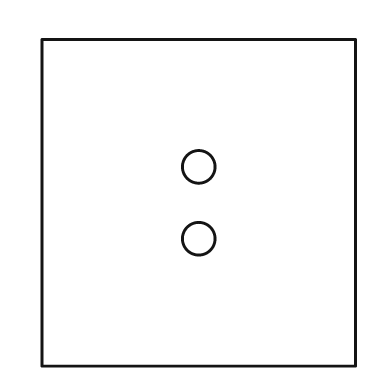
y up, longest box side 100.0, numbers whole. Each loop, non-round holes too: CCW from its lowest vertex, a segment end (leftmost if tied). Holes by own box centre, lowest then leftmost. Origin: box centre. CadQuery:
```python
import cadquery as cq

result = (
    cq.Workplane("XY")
    .moveTo(-48.0, -50.0)
    .lineTo(48.0, -50.0)
    .lineTo(48.0, 50.0)
    .lineTo(-48.0, 50.0)
    .close()
    .moveTo(0.0, -11.0)
    .circle(5.0)
    .moveTo(0.0, 11.0)
    .circle(5.0)
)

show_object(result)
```